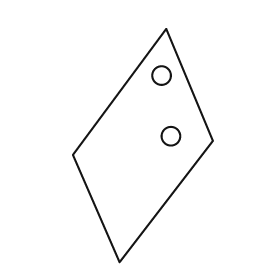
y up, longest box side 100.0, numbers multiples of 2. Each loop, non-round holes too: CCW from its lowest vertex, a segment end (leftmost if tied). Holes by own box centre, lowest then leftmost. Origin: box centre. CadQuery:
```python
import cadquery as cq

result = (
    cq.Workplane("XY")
    .moveTo(-10.0, -50.0)
    .lineTo(30.0, 2.0)
    .lineTo(10.0, 50.0)
    .lineTo(-30.0, -4.0)
    .close()
    .moveTo(12.0, 4.0)
    .circle(4.0)
    .moveTo(8.0, 30.0)
    .circle(4.0)
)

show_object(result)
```